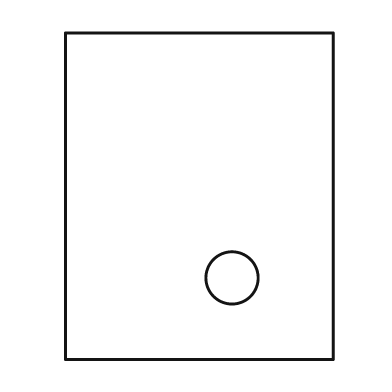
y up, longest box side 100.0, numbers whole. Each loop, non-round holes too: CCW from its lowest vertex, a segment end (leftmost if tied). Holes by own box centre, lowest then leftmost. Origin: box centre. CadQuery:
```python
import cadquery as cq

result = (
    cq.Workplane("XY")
    .moveTo(-41.0, -50.0)
    .lineTo(41.0, -50.0)
    .lineTo(41.0, 50.0)
    .lineTo(-41.0, 50.0)
    .close()
    .moveTo(10.0, -25.0)
    .circle(8.0)
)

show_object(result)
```